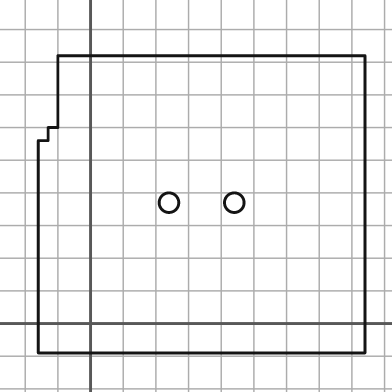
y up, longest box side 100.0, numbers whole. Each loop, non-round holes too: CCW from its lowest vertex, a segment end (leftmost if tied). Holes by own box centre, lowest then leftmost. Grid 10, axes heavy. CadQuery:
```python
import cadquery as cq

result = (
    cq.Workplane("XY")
    .moveTo(-16.0, -9.0)
    .lineTo(84.0, -9.0)
    .lineTo(84.0, 82.0)
    .lineTo(-10.0, 82.0)
    .lineTo(-10.0, 60.0)
    .lineTo(-13.0, 60.0)
    .lineTo(-13.0, 56.0)
    .lineTo(-16.0, 56.0)
    .close()
    .moveTo(24.0, 37.0)
    .circle(3.0)
    .moveTo(44.0, 37.0)
    .circle(3.0)
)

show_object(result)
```